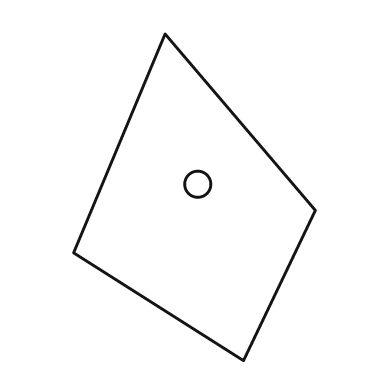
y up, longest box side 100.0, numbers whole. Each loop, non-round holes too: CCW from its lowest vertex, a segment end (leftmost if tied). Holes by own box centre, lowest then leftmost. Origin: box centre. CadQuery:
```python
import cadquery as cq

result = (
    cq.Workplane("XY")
    .moveTo(15.0, -50.0)
    .lineTo(37.0, -4.0)
    .lineTo(-9.0, 50.0)
    .lineTo(-37.0, -17.0)
    .close()
    .moveTo(1.0, 4.0)
    .circle(4.0)
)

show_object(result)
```